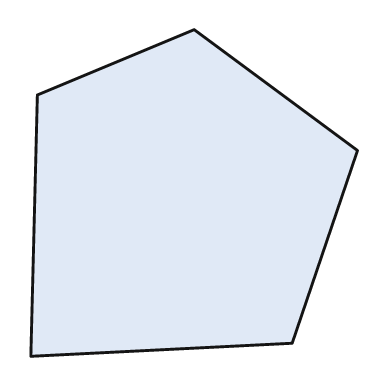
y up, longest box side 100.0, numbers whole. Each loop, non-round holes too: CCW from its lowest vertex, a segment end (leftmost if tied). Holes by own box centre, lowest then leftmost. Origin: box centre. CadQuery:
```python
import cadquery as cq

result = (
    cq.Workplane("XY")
    .moveTo(-50.0, -50.0)
    .lineTo(30.0, -46.0)
    .lineTo(50.0, 13.0)
    .lineTo(0.0, 50.0)
    .lineTo(-48.0, 30.0)
    .close()
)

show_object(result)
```